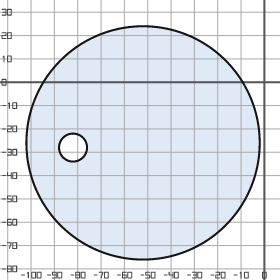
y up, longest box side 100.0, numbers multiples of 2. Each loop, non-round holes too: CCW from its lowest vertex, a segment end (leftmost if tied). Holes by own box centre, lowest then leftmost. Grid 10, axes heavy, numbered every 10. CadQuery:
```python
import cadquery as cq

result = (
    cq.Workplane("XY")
    .moveTo(-52.0, -26.0)
    .circle(50.0)
    .moveTo(-82.0, -28.0)
    .circle(6.0)
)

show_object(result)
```